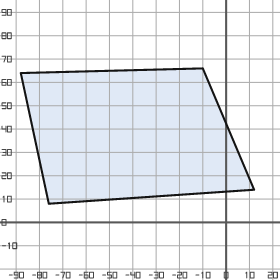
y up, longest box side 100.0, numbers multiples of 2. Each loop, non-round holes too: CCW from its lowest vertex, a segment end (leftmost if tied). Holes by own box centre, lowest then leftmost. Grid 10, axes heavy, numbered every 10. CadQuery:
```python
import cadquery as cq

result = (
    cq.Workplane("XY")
    .moveTo(-76.0, 8.0)
    .lineTo(12.0, 14.0)
    .lineTo(-10.0, 66.0)
    .lineTo(-88.0, 64.0)
    .close()
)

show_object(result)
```